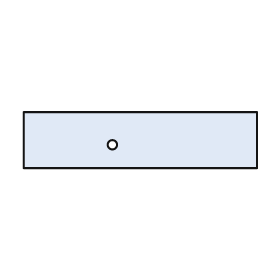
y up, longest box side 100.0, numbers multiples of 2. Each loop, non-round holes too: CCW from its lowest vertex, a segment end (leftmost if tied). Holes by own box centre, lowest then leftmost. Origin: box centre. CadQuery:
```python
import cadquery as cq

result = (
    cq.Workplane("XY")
    .moveTo(-50.0, -12.0)
    .lineTo(50.0, -12.0)
    .lineTo(50.0, 12.0)
    .lineTo(-50.0, 12.0)
    .close()
    .moveTo(-12.0, -2.0)
    .circle(2.0)
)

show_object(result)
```